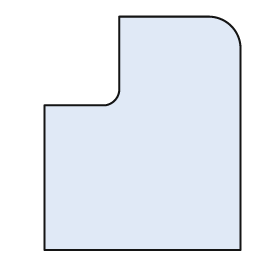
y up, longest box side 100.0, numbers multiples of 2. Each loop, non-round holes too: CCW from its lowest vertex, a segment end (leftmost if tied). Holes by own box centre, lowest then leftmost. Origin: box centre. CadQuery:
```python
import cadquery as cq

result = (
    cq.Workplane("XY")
    .moveTo(-42.0, -50.0)
    .lineTo(42.0, -50.0)
    .lineTo(42.0, 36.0)
    .threePointArc((38.0, 46.0), (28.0, 50.0))
    .lineTo(-10.0, 50.0)
    .lineTo(-10.0, 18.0)
    .threePointArc((-12.0, 14.0), (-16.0, 12.0))
    .lineTo(-42.0, 12.0)
    .close()
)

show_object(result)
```